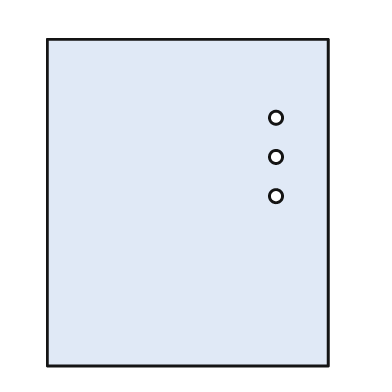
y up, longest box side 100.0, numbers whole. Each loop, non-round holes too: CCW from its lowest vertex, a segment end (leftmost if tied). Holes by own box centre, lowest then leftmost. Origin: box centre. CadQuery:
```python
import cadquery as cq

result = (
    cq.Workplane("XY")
    .moveTo(-43.0, -50.0)
    .lineTo(43.0, -50.0)
    .lineTo(43.0, 50.0)
    .lineTo(-43.0, 50.0)
    .close()
    .moveTo(27.0, 2.0)
    .circle(2.0)
    .moveTo(27.0, 14.0)
    .circle(2.0)
    .moveTo(27.0, 26.0)
    .circle(2.0)
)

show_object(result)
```